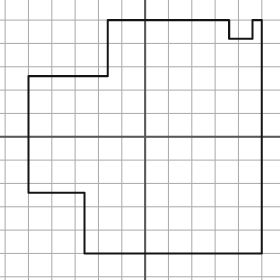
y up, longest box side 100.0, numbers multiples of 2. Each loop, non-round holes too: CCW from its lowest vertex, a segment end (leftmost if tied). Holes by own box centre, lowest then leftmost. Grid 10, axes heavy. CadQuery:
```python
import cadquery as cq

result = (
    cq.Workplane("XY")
    .moveTo(-26.0, -50.0)
    .lineTo(50.0, -50.0)
    .lineTo(50.0, 50.0)
    .lineTo(46.0, 50.0)
    .lineTo(46.0, 42.0)
    .lineTo(36.0, 42.0)
    .lineTo(36.0, 50.0)
    .lineTo(-16.0, 50.0)
    .lineTo(-16.0, 26.0)
    .lineTo(-50.0, 26.0)
    .lineTo(-50.0, -24.0)
    .lineTo(-26.0, -24.0)
    .close()
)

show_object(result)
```